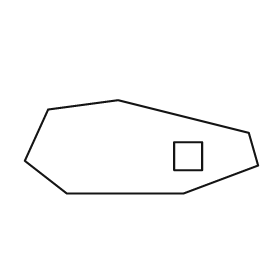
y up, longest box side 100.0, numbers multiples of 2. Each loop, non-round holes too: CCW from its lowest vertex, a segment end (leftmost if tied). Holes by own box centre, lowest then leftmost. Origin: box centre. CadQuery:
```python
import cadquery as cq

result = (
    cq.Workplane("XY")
    .moveTo(-32.0, -20.0)
    .lineTo(18.0, -20.0)
    .lineTo(50.0, -8.0)
    .lineTo(46.0, 6.0)
    .lineTo(-10.0, 20.0)
    .lineTo(-40.0, 16.0)
    .lineTo(-50.0, -6.0)
    .close()
    .moveTo(14.0, -10.0)
    .lineTo(26.0, -10.0)
    .lineTo(26.0, 2.0)
    .lineTo(14.0, 2.0)
    .close()
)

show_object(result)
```